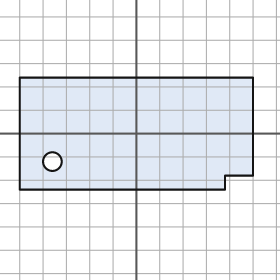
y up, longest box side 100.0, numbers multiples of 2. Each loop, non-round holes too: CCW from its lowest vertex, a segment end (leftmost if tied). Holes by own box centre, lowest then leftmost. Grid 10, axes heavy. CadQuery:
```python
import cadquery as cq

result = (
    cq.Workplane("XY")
    .moveTo(-50.0, -24.0)
    .lineTo(38.0, -24.0)
    .lineTo(38.0, -18.0)
    .lineTo(50.0, -18.0)
    .lineTo(50.0, 24.0)
    .lineTo(-50.0, 24.0)
    .close()
    .moveTo(-36.0, -12.0)
    .circle(4.0)
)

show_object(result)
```